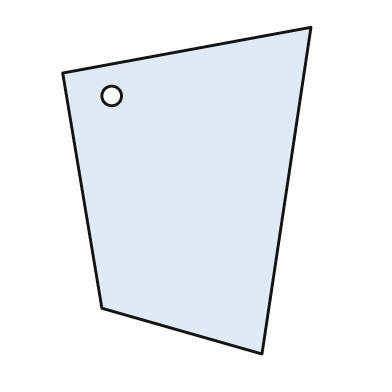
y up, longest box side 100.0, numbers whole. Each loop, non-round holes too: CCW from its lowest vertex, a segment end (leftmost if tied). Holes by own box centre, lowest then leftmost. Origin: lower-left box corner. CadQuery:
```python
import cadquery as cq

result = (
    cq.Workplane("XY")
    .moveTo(61.0, 0.0)
    .lineTo(76.0, 100.0)
    .lineTo(0.0, 86.0)
    .lineTo(12.0, 14.0)
    .close()
    .moveTo(15.0, 79.0)
    .circle(3.0)
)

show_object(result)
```